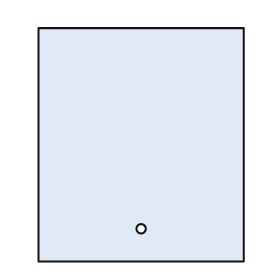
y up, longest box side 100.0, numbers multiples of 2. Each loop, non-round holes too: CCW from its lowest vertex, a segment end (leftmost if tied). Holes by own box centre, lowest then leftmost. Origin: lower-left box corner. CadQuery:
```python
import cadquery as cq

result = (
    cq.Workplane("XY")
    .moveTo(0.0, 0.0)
    .lineTo(88.0, 0.0)
    .lineTo(88.0, 100.0)
    .lineTo(0.0, 100.0)
    .close()
    .moveTo(44.0, 14.0)
    .circle(2.0)
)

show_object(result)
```